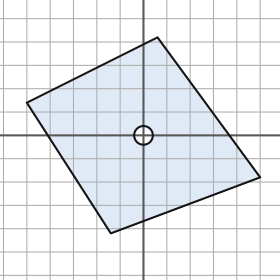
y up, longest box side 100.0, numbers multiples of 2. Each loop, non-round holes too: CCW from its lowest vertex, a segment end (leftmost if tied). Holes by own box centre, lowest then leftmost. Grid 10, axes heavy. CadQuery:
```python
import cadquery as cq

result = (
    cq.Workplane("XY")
    .moveTo(-14.0, -42.0)
    .lineTo(50.0, -18.0)
    .lineTo(6.0, 42.0)
    .lineTo(-50.0, 14.0)
    .close()
    .moveTo(0.0, 0.0)
    .circle(4.0)
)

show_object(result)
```